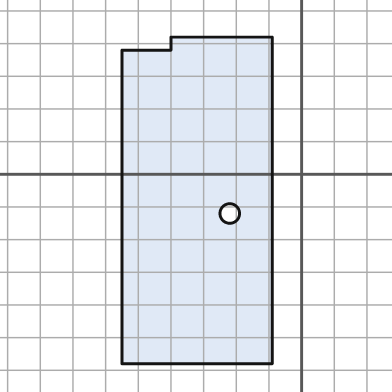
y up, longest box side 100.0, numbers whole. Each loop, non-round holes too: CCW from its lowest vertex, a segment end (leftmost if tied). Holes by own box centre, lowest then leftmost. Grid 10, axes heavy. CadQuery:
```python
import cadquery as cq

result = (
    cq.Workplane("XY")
    .moveTo(-55.0, -58.0)
    .lineTo(-9.0, -58.0)
    .lineTo(-9.0, 42.0)
    .lineTo(-40.0, 42.0)
    .lineTo(-40.0, 38.0)
    .lineTo(-55.0, 38.0)
    .close()
    .moveTo(-22.0, -12.0)
    .circle(3.0)
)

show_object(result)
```